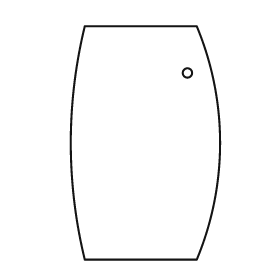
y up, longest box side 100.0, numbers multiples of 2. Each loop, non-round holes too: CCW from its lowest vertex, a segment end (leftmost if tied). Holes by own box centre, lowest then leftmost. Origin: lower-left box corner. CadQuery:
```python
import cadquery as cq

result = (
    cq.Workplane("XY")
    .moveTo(6.0, 0.0)
    .lineTo(54.0, 0.0)
    .threePointArc((64.0, 50.0), (54.0, 100.0))
    .lineTo(6.0, 100.0)
    .threePointArc((0.0, 50.0), (6.0, 0.0))
    .close()
    .moveTo(50.0, 80.0)
    .circle(2.0)
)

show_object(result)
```